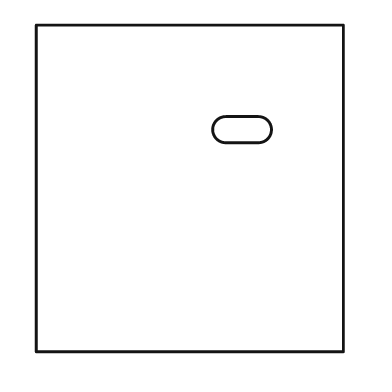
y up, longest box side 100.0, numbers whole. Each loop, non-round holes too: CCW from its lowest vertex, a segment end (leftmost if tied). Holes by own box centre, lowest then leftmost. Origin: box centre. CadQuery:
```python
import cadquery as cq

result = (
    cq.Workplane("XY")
    .moveTo(-47.0, -50.0)
    .lineTo(47.0, -50.0)
    .lineTo(47.0, 50.0)
    .lineTo(-47.0, 50.0)
    .close()
    .moveTo(11.0, 14.0)
    .lineTo(21.0, 14.0)
    .threePointArc((25.0, 18.0), (21.0, 22.0))
    .lineTo(11.0, 22.0)
    .threePointArc((7.0, 18.0), (11.0, 14.0))
    .close()
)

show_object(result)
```